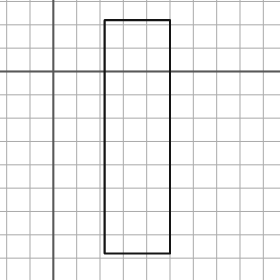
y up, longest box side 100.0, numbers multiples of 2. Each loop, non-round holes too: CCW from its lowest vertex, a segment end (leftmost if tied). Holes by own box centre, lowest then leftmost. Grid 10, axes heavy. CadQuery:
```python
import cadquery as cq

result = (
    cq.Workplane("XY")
    .moveTo(22.0, -78.0)
    .lineTo(50.0, -78.0)
    .lineTo(50.0, 22.0)
    .lineTo(22.0, 22.0)
    .close()
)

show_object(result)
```